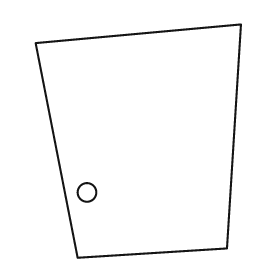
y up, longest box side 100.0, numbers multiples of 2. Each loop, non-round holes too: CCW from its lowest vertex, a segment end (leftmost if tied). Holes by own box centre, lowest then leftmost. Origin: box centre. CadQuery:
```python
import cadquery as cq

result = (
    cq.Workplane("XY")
    .moveTo(-26.0, -50.0)
    .lineTo(38.0, -46.0)
    .lineTo(44.0, 50.0)
    .lineTo(-44.0, 42.0)
    .close()
    .moveTo(-22.0, -22.0)
    .circle(4.0)
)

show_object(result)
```